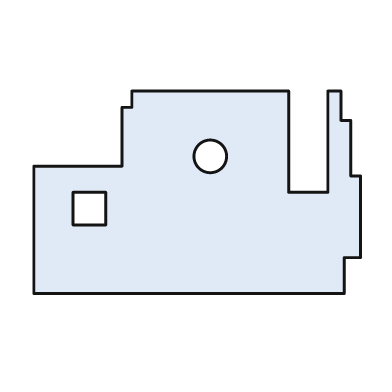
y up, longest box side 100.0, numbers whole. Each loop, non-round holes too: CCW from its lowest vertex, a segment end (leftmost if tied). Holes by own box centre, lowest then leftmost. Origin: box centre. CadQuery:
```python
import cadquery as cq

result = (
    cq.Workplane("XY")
    .moveTo(-50.0, -31.0)
    .lineTo(45.0, -31.0)
    .lineTo(45.0, -20.0)
    .lineTo(50.0, -20.0)
    .lineTo(50.0, 5.0)
    .lineTo(47.0, 5.0)
    .lineTo(47.0, 22.0)
    .lineTo(44.0, 22.0)
    .lineTo(44.0, 31.0)
    .lineTo(40.0, 31.0)
    .lineTo(40.0, 0.0)
    .lineTo(28.0, 0.0)
    .lineTo(28.0, 31.0)
    .lineTo(-20.0, 31.0)
    .lineTo(-20.0, 26.0)
    .lineTo(-23.0, 26.0)
    .lineTo(-23.0, 8.0)
    .lineTo(-50.0, 8.0)
    .close()
    .moveTo(-38.0, -10.0)
    .lineTo(-28.0, -10.0)
    .lineTo(-28.0, 0.0)
    .lineTo(-38.0, 0.0)
    .close()
    .moveTo(4.0, 11.0)
    .circle(5.0)
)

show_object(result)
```